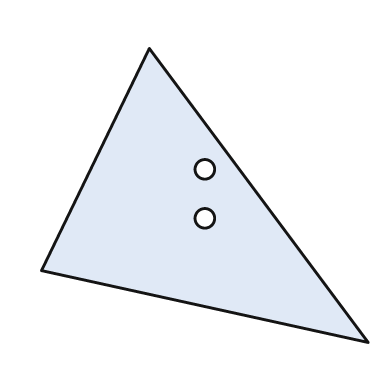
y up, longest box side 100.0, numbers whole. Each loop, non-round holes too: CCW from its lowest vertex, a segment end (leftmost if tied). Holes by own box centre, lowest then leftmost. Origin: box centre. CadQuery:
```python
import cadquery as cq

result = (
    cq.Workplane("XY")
    .moveTo(50.0, -45.0)
    .lineTo(-17.0, 45.0)
    .lineTo(-50.0, -23.0)
    .close()
    .moveTo(0.0, -7.0)
    .circle(3.0)
    .moveTo(0.0, 8.0)
    .circle(3.0)
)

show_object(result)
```